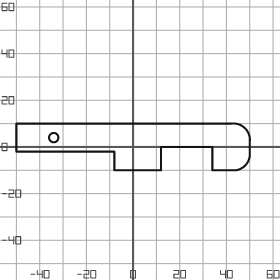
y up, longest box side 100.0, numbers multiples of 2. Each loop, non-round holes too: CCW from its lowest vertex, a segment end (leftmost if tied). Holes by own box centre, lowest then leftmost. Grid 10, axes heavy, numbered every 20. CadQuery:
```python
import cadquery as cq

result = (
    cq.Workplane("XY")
    .moveTo(-8.0, -10.0)
    .lineTo(12.0, -10.0)
    .lineTo(12.0, 0.0)
    .lineTo(34.0, 0.0)
    .lineTo(34.0, -10.0)
    .lineTo(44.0, -10.0)
    .threePointArc((48.0, -8.0), (50.0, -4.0))
    .lineTo(50.0, 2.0)
    .threePointArc((48.0, 8.0), (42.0, 10.0))
    .lineTo(-50.0, 10.0)
    .lineTo(-50.0, -2.0)
    .lineTo(-8.0, -2.0)
    .close()
    .moveTo(-34.0, 4.0)
    .circle(2.0)
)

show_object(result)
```